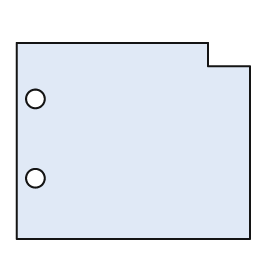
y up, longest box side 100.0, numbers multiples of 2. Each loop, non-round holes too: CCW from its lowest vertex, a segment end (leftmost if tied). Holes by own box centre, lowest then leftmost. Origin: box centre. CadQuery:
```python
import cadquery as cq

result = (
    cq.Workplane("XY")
    .moveTo(-50.0, -42.0)
    .lineTo(50.0, -42.0)
    .lineTo(50.0, 32.0)
    .lineTo(32.0, 32.0)
    .lineTo(32.0, 42.0)
    .lineTo(-50.0, 42.0)
    .close()
    .moveTo(-42.0, -16.0)
    .circle(4.0)
    .moveTo(-42.0, 18.0)
    .circle(4.0)
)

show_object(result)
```